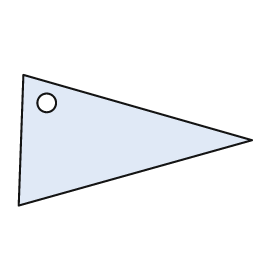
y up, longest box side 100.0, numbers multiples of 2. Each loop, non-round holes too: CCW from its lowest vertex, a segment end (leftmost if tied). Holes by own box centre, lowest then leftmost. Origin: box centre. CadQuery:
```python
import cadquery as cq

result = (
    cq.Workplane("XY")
    .moveTo(-50.0, -28.0)
    .lineTo(50.0, 0.0)
    .lineTo(-48.0, 28.0)
    .close()
    .moveTo(-38.0, 16.0)
    .circle(4.0)
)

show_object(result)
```